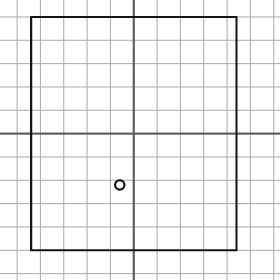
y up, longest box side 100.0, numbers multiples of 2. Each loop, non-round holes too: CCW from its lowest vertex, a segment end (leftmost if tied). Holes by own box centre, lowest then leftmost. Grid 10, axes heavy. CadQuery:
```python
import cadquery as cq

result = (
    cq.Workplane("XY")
    .moveTo(-44.0, -50.0)
    .lineTo(44.0, -50.0)
    .lineTo(44.0, 50.0)
    .lineTo(-44.0, 50.0)
    .close()
    .moveTo(-6.0, -22.0)
    .circle(2.0)
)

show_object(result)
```